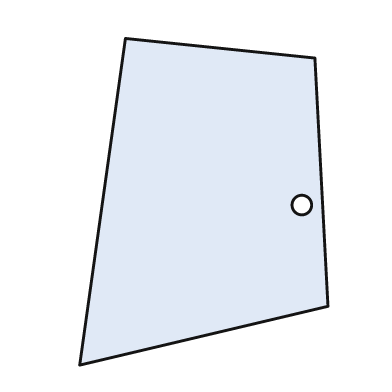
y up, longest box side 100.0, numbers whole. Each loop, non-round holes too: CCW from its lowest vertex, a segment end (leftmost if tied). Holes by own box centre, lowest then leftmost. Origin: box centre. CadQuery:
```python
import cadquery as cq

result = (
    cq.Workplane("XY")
    .moveTo(-38.0, -50.0)
    .lineTo(38.0, -32.0)
    .lineTo(34.0, 44.0)
    .lineTo(-24.0, 50.0)
    .close()
    .moveTo(30.0, -1.0)
    .circle(3.0)
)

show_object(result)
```